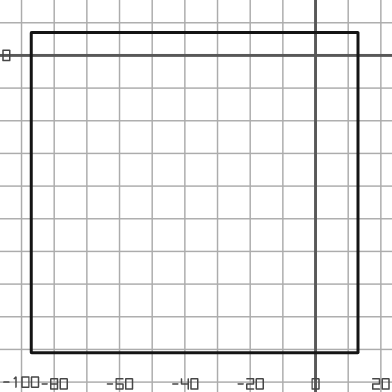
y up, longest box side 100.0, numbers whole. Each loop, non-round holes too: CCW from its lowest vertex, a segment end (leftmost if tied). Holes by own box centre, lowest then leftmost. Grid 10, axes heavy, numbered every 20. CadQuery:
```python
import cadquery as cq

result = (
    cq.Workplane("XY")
    .moveTo(-87.0, -91.0)
    .lineTo(13.0, -91.0)
    .lineTo(13.0, 7.0)
    .lineTo(-87.0, 7.0)
    .close()
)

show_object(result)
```